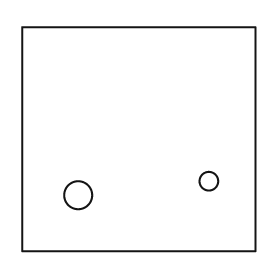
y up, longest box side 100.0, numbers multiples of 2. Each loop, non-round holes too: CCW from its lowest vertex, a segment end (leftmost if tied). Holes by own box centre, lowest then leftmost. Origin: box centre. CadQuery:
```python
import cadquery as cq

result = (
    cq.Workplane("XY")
    .moveTo(-50.0, -48.0)
    .lineTo(50.0, -48.0)
    .lineTo(50.0, 48.0)
    .lineTo(-50.0, 48.0)
    .close()
    .moveTo(-26.0, -24.0)
    .circle(6.0)
    .moveTo(30.0, -18.0)
    .circle(4.0)
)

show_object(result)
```